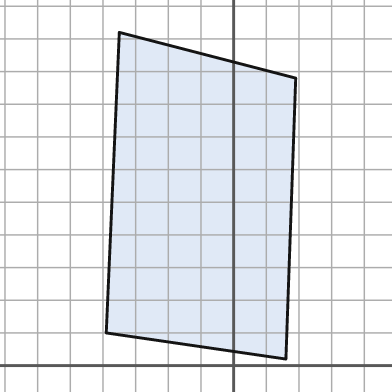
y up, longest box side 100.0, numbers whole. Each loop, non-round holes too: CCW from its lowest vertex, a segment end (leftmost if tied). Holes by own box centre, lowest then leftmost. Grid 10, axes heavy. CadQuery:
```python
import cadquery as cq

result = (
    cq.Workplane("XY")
    .moveTo(16.0, 2.0)
    .lineTo(19.0, 88.0)
    .lineTo(-35.0, 102.0)
    .lineTo(-39.0, 10.0)
    .close()
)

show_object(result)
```